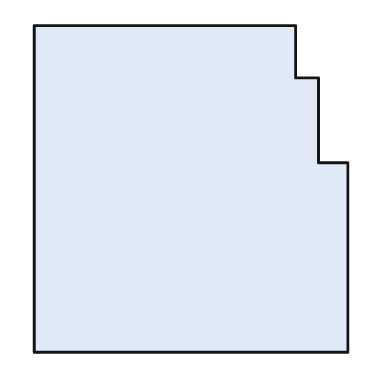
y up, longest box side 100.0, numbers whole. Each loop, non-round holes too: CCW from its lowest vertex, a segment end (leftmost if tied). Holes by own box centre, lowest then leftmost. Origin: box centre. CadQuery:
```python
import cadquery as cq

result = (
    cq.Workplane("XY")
    .moveTo(-48.0, -50.0)
    .lineTo(48.0, -50.0)
    .lineTo(48.0, 8.0)
    .lineTo(39.0, 8.0)
    .lineTo(39.0, 34.0)
    .lineTo(32.0, 34.0)
    .lineTo(32.0, 50.0)
    .lineTo(-48.0, 50.0)
    .close()
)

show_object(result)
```